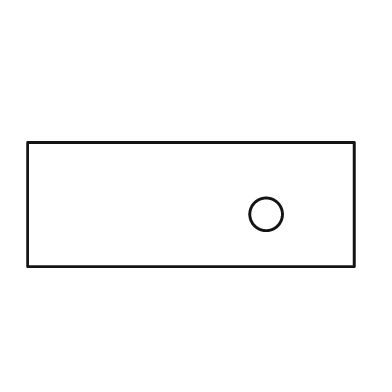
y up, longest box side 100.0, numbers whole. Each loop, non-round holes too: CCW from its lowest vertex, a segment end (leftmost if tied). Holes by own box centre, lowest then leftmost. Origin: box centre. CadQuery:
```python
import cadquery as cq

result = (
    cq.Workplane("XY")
    .moveTo(-50.0, -19.0)
    .lineTo(50.0, -19.0)
    .lineTo(50.0, 19.0)
    .lineTo(-50.0, 19.0)
    .close()
    .moveTo(23.0, -3.0)
    .circle(5.0)
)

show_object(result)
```